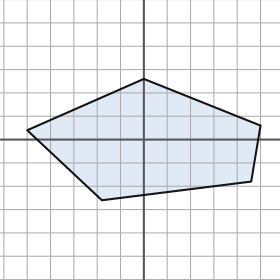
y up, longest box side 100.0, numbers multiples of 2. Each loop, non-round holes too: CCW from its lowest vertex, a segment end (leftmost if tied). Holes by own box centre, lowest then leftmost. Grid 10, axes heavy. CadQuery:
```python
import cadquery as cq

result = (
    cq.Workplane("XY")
    .moveTo(-18.0, -26.0)
    .lineTo(46.0, -18.0)
    .lineTo(50.0, 6.0)
    .lineTo(0.0, 26.0)
    .lineTo(-50.0, 4.0)
    .close()
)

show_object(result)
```